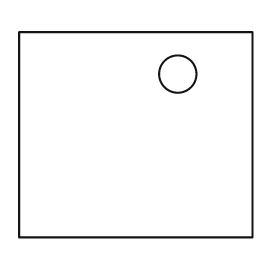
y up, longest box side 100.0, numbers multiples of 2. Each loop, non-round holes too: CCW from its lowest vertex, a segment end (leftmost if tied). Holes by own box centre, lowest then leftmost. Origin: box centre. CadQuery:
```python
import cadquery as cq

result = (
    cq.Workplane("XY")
    .moveTo(-50.0, -44.0)
    .lineTo(50.0, -44.0)
    .lineTo(50.0, 44.0)
    .lineTo(-50.0, 44.0)
    .close()
    .moveTo(18.0, 26.0)
    .circle(8.0)
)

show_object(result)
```